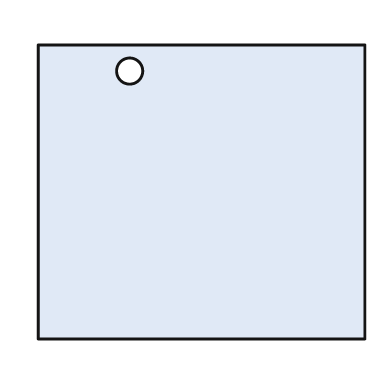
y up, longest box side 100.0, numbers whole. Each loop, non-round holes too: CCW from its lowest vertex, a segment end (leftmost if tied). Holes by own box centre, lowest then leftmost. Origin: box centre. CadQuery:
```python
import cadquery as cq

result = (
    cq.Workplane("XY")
    .moveTo(-50.0, -45.0)
    .lineTo(50.0, -45.0)
    .lineTo(50.0, 45.0)
    .lineTo(-50.0, 45.0)
    .close()
    .moveTo(-22.0, 37.0)
    .circle(4.0)
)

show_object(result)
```